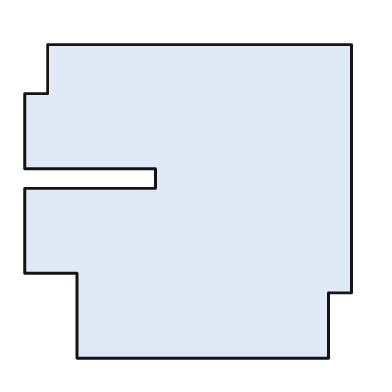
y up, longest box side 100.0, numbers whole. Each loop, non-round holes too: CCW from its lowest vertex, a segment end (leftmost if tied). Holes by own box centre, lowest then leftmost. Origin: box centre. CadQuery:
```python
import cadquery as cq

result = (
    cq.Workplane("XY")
    .moveTo(-34.0, -48.0)
    .lineTo(43.0, -48.0)
    .lineTo(43.0, -28.0)
    .lineTo(50.0, -28.0)
    .lineTo(50.0, 48.0)
    .lineTo(-43.0, 48.0)
    .lineTo(-43.0, 33.0)
    .lineTo(-50.0, 33.0)
    .lineTo(-50.0, 10.0)
    .lineTo(-10.0, 10.0)
    .lineTo(-10.0, 4.0)
    .lineTo(-50.0, 4.0)
    .lineTo(-50.0, -22.0)
    .lineTo(-34.0, -22.0)
    .close()
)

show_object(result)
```